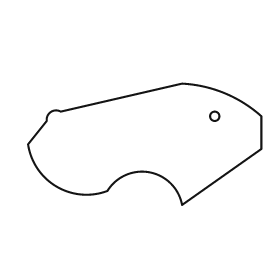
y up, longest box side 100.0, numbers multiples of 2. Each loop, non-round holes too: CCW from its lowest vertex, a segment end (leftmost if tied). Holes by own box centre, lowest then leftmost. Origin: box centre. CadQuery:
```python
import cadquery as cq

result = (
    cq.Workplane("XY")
    .moveTo(16.0, -26.0)
    .lineTo(50.0, -2.0)
    .lineTo(50.0, 12.0)
    .threePointArc((34.0, 22.0), (16.0, 26.0))
    .lineTo(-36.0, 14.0)
    .threePointArc((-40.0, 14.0), (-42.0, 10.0))
    .lineTo(-50.0, 0.0)
    .threePointArc((-38.0, -18.0), (-16.0, -20.0))
    .threePointArc((2.0, -12.0), (16.0, -26.0))
    .close()
    .moveTo(30.0, 12.0)
    .circle(2.0)
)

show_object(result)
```